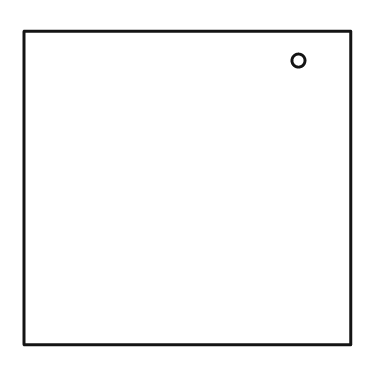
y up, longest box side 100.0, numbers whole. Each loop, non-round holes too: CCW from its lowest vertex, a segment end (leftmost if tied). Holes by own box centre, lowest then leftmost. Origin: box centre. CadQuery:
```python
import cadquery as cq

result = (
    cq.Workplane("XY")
    .moveTo(-50.0, -48.0)
    .lineTo(50.0, -48.0)
    .lineTo(50.0, 48.0)
    .lineTo(-50.0, 48.0)
    .close()
    .moveTo(34.0, 39.0)
    .circle(2.0)
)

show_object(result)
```